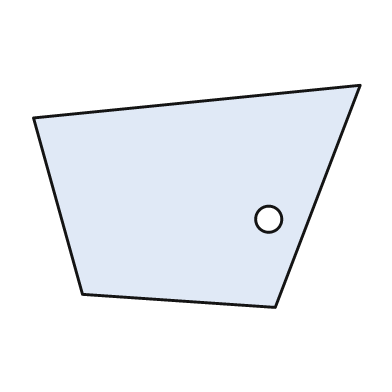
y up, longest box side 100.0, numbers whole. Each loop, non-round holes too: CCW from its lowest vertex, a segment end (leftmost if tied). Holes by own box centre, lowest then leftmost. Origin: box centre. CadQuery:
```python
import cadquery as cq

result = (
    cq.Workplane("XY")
    .moveTo(24.0, -34.0)
    .lineTo(50.0, 34.0)
    .lineTo(-50.0, 24.0)
    .lineTo(-35.0, -30.0)
    .close()
    .moveTo(22.0, -7.0)
    .circle(4.0)
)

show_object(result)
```